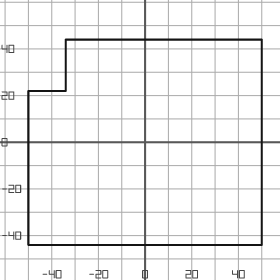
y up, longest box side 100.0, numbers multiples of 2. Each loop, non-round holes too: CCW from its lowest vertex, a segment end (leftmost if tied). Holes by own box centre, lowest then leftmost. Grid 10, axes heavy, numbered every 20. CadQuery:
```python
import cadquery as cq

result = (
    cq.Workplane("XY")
    .moveTo(-50.0, -44.0)
    .lineTo(50.0, -44.0)
    .lineTo(50.0, 44.0)
    .lineTo(-34.0, 44.0)
    .lineTo(-34.0, 22.0)
    .lineTo(-50.0, 22.0)
    .close()
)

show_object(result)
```